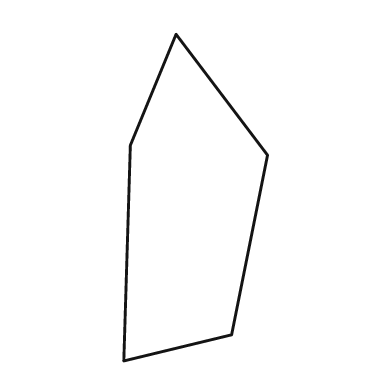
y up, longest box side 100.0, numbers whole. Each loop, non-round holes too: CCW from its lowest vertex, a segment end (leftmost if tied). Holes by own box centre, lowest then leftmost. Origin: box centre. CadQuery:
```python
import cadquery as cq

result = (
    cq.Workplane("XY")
    .moveTo(-22.0, -50.0)
    .lineTo(11.0, -42.0)
    .lineTo(22.0, 13.0)
    .lineTo(-6.0, 50.0)
    .lineTo(-20.0, 16.0)
    .close()
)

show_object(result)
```